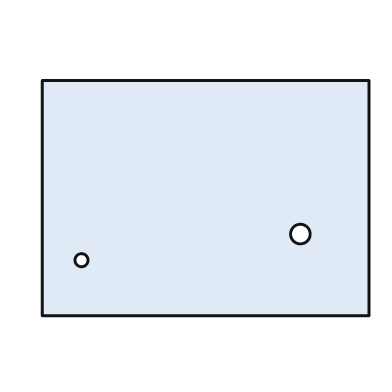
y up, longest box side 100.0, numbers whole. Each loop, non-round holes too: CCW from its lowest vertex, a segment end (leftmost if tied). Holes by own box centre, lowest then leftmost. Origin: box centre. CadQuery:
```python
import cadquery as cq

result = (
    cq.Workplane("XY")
    .moveTo(-50.0, -36.0)
    .lineTo(50.0, -36.0)
    .lineTo(50.0, 36.0)
    .lineTo(-50.0, 36.0)
    .close()
    .moveTo(-38.0, -19.0)
    .circle(2.0)
    .moveTo(29.0, -11.0)
    .circle(3.0)
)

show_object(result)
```